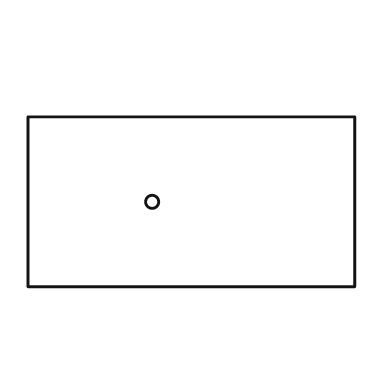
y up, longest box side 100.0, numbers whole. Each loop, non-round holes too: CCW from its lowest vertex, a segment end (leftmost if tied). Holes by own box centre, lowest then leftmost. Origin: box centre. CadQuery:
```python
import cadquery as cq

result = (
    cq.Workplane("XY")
    .moveTo(-50.0, -26.0)
    .lineTo(50.0, -26.0)
    .lineTo(50.0, 26.0)
    .lineTo(-50.0, 26.0)
    .close()
    .moveTo(-12.0, 0.0)
    .circle(2.0)
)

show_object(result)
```